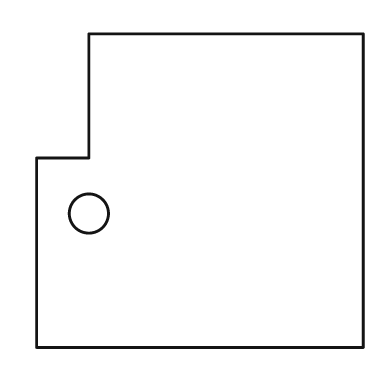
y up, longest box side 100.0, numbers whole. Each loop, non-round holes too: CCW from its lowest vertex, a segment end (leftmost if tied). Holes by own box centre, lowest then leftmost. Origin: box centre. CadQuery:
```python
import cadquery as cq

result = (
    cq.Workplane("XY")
    .moveTo(-50.0, -48.0)
    .lineTo(50.0, -48.0)
    .lineTo(50.0, 48.0)
    .lineTo(-34.0, 48.0)
    .lineTo(-34.0, 10.0)
    .lineTo(-50.0, 10.0)
    .close()
    .moveTo(-34.0, -7.0)
    .circle(6.0)
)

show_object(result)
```